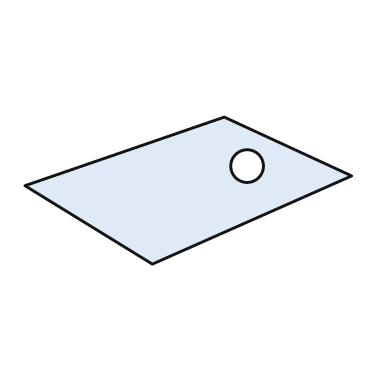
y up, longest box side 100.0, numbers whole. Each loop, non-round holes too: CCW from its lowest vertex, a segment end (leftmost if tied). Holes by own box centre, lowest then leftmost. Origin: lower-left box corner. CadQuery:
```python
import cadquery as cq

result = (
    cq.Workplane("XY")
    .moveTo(39.0, 0.0)
    .lineTo(100.0, 27.0)
    .lineTo(61.0, 45.0)
    .lineTo(0.0, 24.0)
    .close()
    .moveTo(68.0, 30.0)
    .circle(5.0)
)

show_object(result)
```